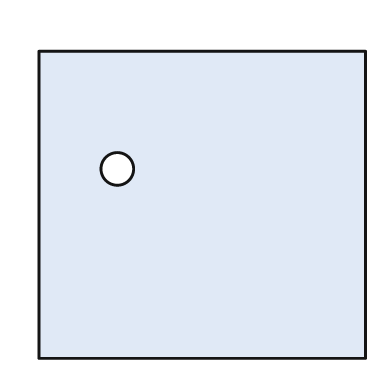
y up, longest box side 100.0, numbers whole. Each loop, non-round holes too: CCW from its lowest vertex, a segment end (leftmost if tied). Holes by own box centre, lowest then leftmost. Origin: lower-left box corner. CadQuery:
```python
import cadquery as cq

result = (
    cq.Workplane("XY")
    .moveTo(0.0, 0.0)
    .lineTo(100.0, 0.0)
    .lineTo(100.0, 94.0)
    .lineTo(0.0, 94.0)
    .close()
    .moveTo(24.0, 58.0)
    .circle(5.0)
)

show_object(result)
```